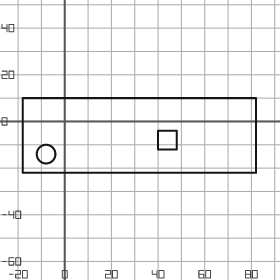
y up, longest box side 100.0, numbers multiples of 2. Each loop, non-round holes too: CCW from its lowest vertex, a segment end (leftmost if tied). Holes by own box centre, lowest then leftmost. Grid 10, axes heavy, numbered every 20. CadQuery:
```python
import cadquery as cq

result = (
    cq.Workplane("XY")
    .moveTo(-18.0, -22.0)
    .lineTo(82.0, -22.0)
    .lineTo(82.0, 10.0)
    .lineTo(-18.0, 10.0)
    .close()
    .moveTo(-8.0, -14.0)
    .circle(4.0)
    .moveTo(40.0, -12.0)
    .lineTo(48.0, -12.0)
    .lineTo(48.0, -4.0)
    .lineTo(40.0, -4.0)
    .close()
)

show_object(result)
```